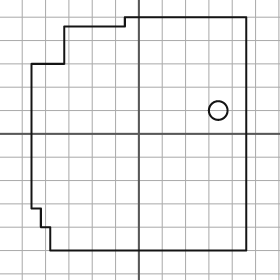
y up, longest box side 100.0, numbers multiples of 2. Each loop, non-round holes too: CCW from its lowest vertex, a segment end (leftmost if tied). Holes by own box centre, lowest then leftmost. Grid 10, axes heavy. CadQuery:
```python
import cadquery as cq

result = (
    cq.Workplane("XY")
    .moveTo(-38.0, -50.0)
    .lineTo(46.0, -50.0)
    .lineTo(46.0, 50.0)
    .lineTo(-6.0, 50.0)
    .lineTo(-6.0, 46.0)
    .lineTo(-32.0, 46.0)
    .lineTo(-32.0, 30.0)
    .lineTo(-46.0, 30.0)
    .lineTo(-46.0, -32.0)
    .lineTo(-42.0, -32.0)
    .lineTo(-42.0, -40.0)
    .lineTo(-38.0, -40.0)
    .close()
    .moveTo(34.0, 10.0)
    .circle(4.0)
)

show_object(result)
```